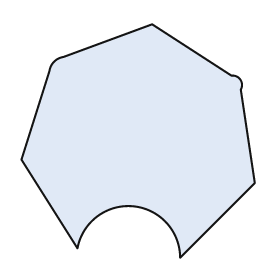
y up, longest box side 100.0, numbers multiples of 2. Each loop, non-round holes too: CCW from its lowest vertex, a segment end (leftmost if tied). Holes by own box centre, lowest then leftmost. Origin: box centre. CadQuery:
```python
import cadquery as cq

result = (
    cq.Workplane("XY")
    .moveTo(18.0, -50.0)
    .lineTo(50.0, -18.0)
    .lineTo(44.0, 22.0)
    .threePointArc((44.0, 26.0), (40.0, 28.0))
    .lineTo(6.0, 50.0)
    .lineTo(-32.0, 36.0)
    .threePointArc((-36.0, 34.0), (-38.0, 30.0))
    .lineTo(-50.0, -8.0)
    .lineTo(-26.0, -46.0)
    .threePointArc((-2.0, -28.0), (18.0, -50.0))
    .close()
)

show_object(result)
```